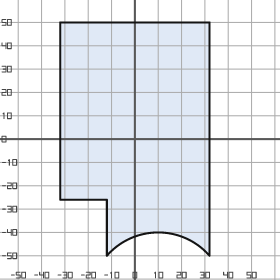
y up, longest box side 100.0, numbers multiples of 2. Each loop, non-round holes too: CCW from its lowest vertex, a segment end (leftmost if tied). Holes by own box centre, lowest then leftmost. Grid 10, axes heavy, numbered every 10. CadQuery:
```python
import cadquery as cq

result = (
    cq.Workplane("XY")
    .moveTo(-12.0, -50.0)
    .threePointArc((10.0, -40.0), (32.0, -50.0))
    .lineTo(32.0, 50.0)
    .lineTo(-32.0, 50.0)
    .lineTo(-32.0, -26.0)
    .lineTo(-12.0, -26.0)
    .close()
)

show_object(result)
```